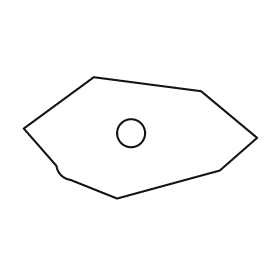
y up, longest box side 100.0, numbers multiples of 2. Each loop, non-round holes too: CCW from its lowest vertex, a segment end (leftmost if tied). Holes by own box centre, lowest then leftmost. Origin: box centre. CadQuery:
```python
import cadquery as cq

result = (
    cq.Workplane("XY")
    .moveTo(-10.0, -26.0)
    .lineTo(34.0, -14.0)
    .lineTo(50.0, 0.0)
    .lineTo(26.0, 20.0)
    .lineTo(-20.0, 26.0)
    .lineTo(-50.0, 4.0)
    .lineTo(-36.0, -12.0)
    .threePointArc((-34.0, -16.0), (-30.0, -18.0))
    .close()
    .moveTo(-4.0, 2.0)
    .circle(6.0)
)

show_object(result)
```